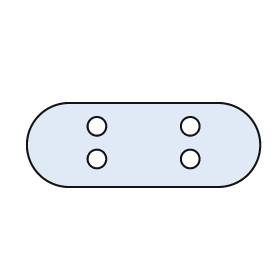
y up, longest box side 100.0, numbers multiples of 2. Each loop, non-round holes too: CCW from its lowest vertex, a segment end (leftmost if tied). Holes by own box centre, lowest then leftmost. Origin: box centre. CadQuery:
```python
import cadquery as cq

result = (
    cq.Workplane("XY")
    .moveTo(-32.0, -18.0)
    .lineTo(32.0, -18.0)
    .threePointArc((50.0, 0.0), (32.0, 18.0))
    .lineTo(-32.0, 18.0)
    .threePointArc((-50.0, 0.0), (-32.0, -18.0))
    .close()
    .moveTo(-20.0, -6.0)
    .circle(4.0)
    .moveTo(20.0, -6.0)
    .circle(4.0)
    .moveTo(-20.0, 8.0)
    .circle(4.0)
    .moveTo(20.0, 8.0)
    .circle(4.0)
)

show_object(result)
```